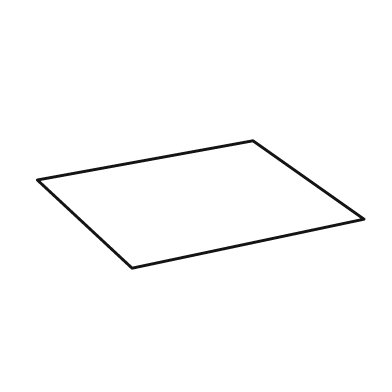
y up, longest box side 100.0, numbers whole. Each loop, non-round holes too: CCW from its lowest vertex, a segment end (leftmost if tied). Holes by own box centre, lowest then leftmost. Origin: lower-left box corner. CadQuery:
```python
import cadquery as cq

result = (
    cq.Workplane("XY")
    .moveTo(29.0, 0.0)
    .lineTo(100.0, 15.0)
    .lineTo(66.0, 39.0)
    .lineTo(0.0, 27.0)
    .close()
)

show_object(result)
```